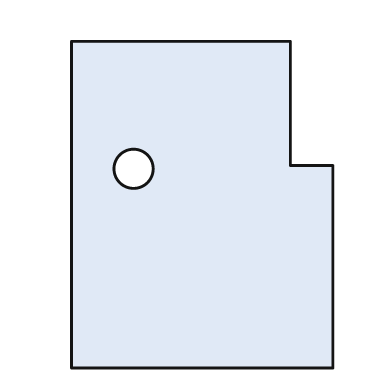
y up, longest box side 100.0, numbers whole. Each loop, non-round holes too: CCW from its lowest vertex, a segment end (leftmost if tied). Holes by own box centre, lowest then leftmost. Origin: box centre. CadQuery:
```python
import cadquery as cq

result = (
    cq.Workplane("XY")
    .moveTo(-40.0, -50.0)
    .lineTo(40.0, -50.0)
    .lineTo(40.0, 12.0)
    .lineTo(27.0, 12.0)
    .lineTo(27.0, 50.0)
    .lineTo(-40.0, 50.0)
    .close()
    .moveTo(-21.0, 11.0)
    .circle(6.0)
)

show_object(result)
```